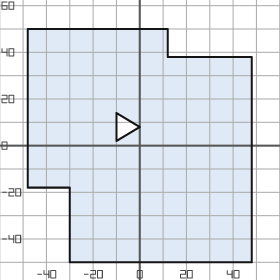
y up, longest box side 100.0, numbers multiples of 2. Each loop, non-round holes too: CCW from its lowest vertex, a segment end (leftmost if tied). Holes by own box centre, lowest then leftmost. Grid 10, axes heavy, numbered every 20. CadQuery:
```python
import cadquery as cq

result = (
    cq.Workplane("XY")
    .moveTo(-30.0, -50.0)
    .lineTo(48.0, -50.0)
    .lineTo(48.0, 38.0)
    .lineTo(12.0, 38.0)
    .lineTo(12.0, 50.0)
    .lineTo(-48.0, 50.0)
    .lineTo(-48.0, -18.0)
    .lineTo(-30.0, -18.0)
    .close()
    .moveTo(-10.0, 2.0)
    .lineTo(0.0, 8.0)
    .lineTo(-10.0, 14.0)
    .close()
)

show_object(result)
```